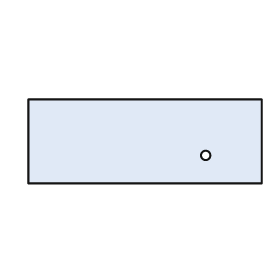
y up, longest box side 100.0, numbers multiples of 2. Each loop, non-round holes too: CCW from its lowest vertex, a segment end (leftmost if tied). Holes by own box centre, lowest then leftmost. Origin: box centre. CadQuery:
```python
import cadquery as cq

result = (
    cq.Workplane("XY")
    .moveTo(-50.0, -18.0)
    .lineTo(50.0, -18.0)
    .lineTo(50.0, 18.0)
    .lineTo(-50.0, 18.0)
    .close()
    .moveTo(26.0, -6.0)
    .circle(2.0)
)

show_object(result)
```